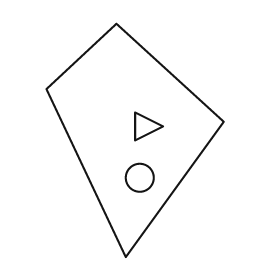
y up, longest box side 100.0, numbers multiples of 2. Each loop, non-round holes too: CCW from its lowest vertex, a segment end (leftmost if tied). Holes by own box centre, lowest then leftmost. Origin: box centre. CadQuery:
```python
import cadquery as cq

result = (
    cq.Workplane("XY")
    .moveTo(-4.0, -50.0)
    .lineTo(38.0, 8.0)
    .lineTo(-8.0, 50.0)
    .lineTo(-38.0, 22.0)
    .close()
    .moveTo(2.0, -16.0)
    .circle(6.0)
    .moveTo(0.0, 0.0)
    .lineTo(12.0, 6.0)
    .lineTo(0.0, 12.0)
    .close()
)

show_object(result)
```